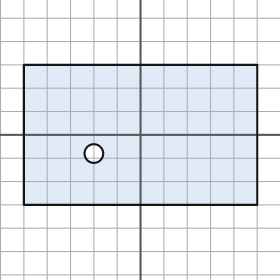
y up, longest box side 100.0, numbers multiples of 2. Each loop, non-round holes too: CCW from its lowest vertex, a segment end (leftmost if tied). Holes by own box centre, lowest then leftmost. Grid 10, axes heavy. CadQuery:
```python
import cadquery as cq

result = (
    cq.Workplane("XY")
    .moveTo(-50.0, -30.0)
    .lineTo(50.0, -30.0)
    .lineTo(50.0, 30.0)
    .lineTo(-50.0, 30.0)
    .close()
    .moveTo(-20.0, -8.0)
    .circle(4.0)
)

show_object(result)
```